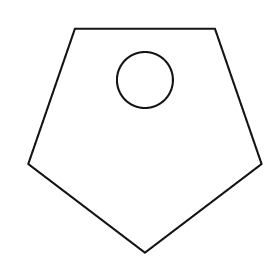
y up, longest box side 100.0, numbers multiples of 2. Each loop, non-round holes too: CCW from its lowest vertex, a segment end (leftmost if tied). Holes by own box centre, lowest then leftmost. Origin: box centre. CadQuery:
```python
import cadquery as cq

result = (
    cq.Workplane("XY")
    .moveTo(0.0, -48.0)
    .lineTo(50.0, -10.0)
    .lineTo(30.0, 48.0)
    .lineTo(-30.0, 48.0)
    .lineTo(-50.0, -10.0)
    .close()
    .moveTo(0.0, 26.0)
    .circle(12.0)
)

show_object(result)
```